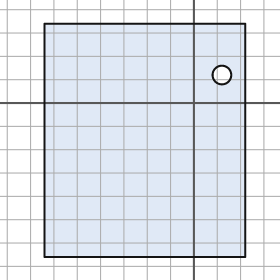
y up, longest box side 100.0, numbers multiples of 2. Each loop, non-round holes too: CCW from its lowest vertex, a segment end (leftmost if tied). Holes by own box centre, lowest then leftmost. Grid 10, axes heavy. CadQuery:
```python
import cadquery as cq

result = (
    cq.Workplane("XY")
    .moveTo(-64.0, -66.0)
    .lineTo(22.0, -66.0)
    .lineTo(22.0, 34.0)
    .lineTo(-64.0, 34.0)
    .close()
    .moveTo(12.0, 12.0)
    .circle(4.0)
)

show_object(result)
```